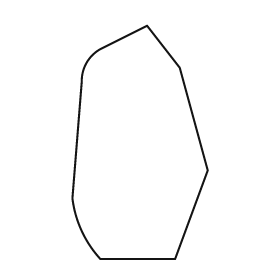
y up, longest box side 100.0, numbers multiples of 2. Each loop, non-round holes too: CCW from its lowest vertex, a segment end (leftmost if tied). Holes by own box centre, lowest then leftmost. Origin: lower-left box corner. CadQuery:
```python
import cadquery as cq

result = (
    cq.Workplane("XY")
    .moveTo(12.0, 0.0)
    .lineTo(44.0, 0.0)
    .lineTo(58.0, 38.0)
    .lineTo(46.0, 82.0)
    .lineTo(32.0, 100.0)
    .lineTo(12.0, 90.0)
    .threePointArc((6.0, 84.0), (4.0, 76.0))
    .lineTo(0.0, 26.0)
    .threePointArc((4.0, 12.0), (12.0, 0.0))
    .close()
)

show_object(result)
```